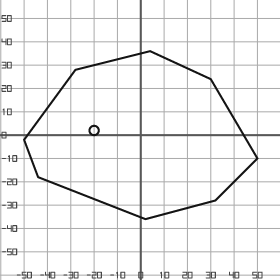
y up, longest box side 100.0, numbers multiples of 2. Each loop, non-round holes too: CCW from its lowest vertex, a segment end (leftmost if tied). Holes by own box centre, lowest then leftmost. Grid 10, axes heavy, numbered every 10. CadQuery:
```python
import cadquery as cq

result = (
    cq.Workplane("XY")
    .moveTo(2.0, -36.0)
    .lineTo(32.0, -28.0)
    .lineTo(50.0, -10.0)
    .lineTo(30.0, 24.0)
    .lineTo(4.0, 36.0)
    .lineTo(-28.0, 28.0)
    .lineTo(-50.0, -2.0)
    .lineTo(-44.0, -18.0)
    .close()
    .moveTo(-20.0, 2.0)
    .circle(2.0)
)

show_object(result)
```